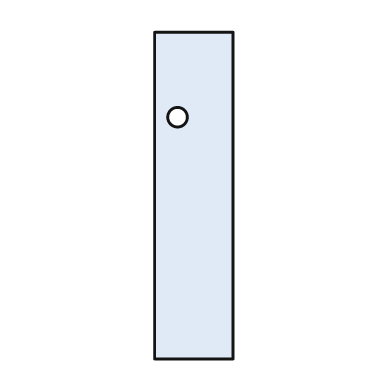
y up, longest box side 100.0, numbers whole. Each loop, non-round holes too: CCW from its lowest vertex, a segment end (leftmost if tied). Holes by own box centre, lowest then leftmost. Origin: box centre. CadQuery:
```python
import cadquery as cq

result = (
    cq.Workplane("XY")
    .moveTo(-12.0, -50.0)
    .lineTo(12.0, -50.0)
    .lineTo(12.0, 50.0)
    .lineTo(-12.0, 50.0)
    .close()
    .moveTo(-5.0, 24.0)
    .circle(3.0)
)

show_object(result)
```